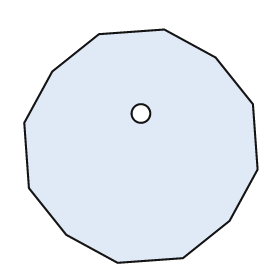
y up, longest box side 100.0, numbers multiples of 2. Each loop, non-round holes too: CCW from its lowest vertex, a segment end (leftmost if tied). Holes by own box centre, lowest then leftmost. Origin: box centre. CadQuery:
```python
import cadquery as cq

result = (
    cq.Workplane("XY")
    .moveTo(-10.0, -50.0)
    .lineTo(18.0, -48.0)
    .lineTo(38.0, -32.0)
    .lineTo(50.0, -10.0)
    .lineTo(48.0, 18.0)
    .lineTo(32.0, 38.0)
    .lineTo(10.0, 50.0)
    .lineTo(-18.0, 48.0)
    .lineTo(-38.0, 32.0)
    .lineTo(-50.0, 10.0)
    .lineTo(-48.0, -18.0)
    .lineTo(-32.0, -38.0)
    .close()
    .moveTo(0.0, 14.0)
    .circle(4.0)
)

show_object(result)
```